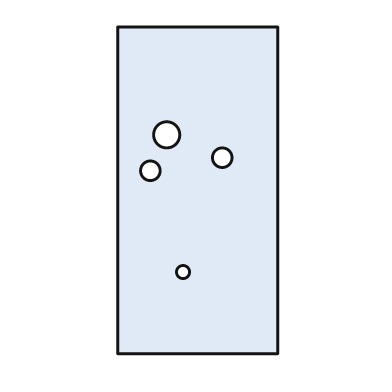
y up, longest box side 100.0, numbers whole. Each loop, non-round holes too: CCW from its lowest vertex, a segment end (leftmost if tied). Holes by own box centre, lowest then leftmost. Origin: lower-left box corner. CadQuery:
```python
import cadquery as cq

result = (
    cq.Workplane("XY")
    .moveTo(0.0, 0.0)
    .lineTo(49.0, 0.0)
    .lineTo(49.0, 100.0)
    .lineTo(0.0, 100.0)
    .close()
    .moveTo(20.0, 25.0)
    .circle(2.0)
    .moveTo(10.0, 56.0)
    .circle(3.0)
    .moveTo(32.0, 60.0)
    .circle(3.0)
    .moveTo(15.0, 67.0)
    .circle(4.0)
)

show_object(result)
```